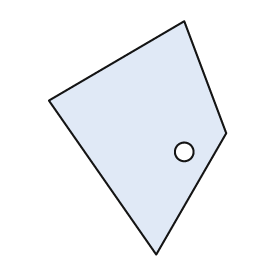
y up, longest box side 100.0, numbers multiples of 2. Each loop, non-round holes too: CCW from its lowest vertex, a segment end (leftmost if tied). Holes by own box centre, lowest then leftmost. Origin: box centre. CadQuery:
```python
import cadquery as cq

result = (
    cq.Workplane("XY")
    .moveTo(8.0, -50.0)
    .lineTo(38.0, 2.0)
    .lineTo(20.0, 50.0)
    .lineTo(-38.0, 16.0)
    .close()
    .moveTo(20.0, -6.0)
    .circle(4.0)
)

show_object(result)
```